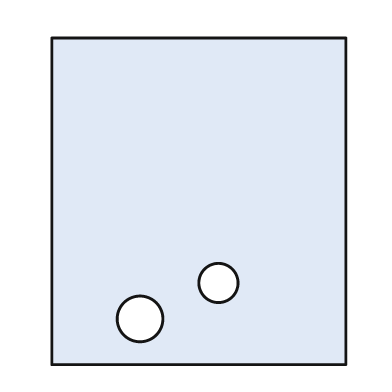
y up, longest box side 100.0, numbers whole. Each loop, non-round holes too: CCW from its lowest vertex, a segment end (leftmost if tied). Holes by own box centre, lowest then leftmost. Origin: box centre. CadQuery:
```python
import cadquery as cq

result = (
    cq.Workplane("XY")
    .moveTo(-45.0, -50.0)
    .lineTo(45.0, -50.0)
    .lineTo(45.0, 50.0)
    .lineTo(-45.0, 50.0)
    .close()
    .moveTo(-18.0, -36.0)
    .circle(7.0)
    .moveTo(6.0, -25.0)
    .circle(6.0)
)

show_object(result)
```